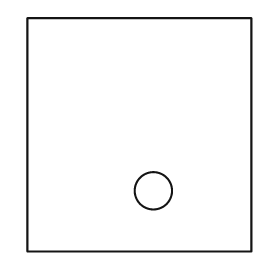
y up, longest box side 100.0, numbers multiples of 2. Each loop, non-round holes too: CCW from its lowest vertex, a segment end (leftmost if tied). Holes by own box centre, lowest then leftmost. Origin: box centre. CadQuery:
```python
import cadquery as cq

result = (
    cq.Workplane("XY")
    .moveTo(-48.0, -50.0)
    .lineTo(48.0, -50.0)
    .lineTo(48.0, 50.0)
    .lineTo(-48.0, 50.0)
    .close()
    .moveTo(6.0, -24.0)
    .circle(8.0)
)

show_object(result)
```